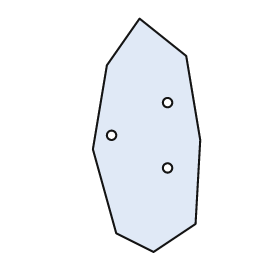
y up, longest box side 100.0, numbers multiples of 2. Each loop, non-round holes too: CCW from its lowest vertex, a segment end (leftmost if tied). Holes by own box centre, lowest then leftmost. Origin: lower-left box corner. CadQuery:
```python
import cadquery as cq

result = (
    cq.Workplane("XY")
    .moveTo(26.0, 0.0)
    .lineTo(44.0, 12.0)
    .lineTo(46.0, 48.0)
    .lineTo(40.0, 84.0)
    .lineTo(20.0, 100.0)
    .lineTo(6.0, 80.0)
    .lineTo(0.0, 44.0)
    .lineTo(10.0, 8.0)
    .close()
    .moveTo(32.0, 36.0)
    .circle(2.0)
    .moveTo(8.0, 50.0)
    .circle(2.0)
    .moveTo(32.0, 64.0)
    .circle(2.0)
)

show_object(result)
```